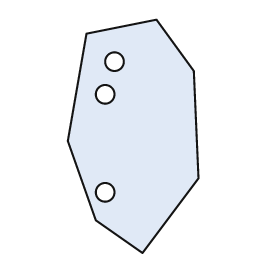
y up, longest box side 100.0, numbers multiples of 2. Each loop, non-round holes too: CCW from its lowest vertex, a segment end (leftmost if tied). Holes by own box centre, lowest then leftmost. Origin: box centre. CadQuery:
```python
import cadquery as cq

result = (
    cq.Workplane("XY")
    .moveTo(4.0, -50.0)
    .lineTo(28.0, -18.0)
    .lineTo(26.0, 28.0)
    .lineTo(10.0, 50.0)
    .lineTo(-20.0, 44.0)
    .lineTo(-28.0, -2.0)
    .lineTo(-16.0, -36.0)
    .close()
    .moveTo(-12.0, -24.0)
    .circle(4.0)
    .moveTo(-12.0, 18.0)
    .circle(4.0)
    .moveTo(-8.0, 32.0)
    .circle(4.0)
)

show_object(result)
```